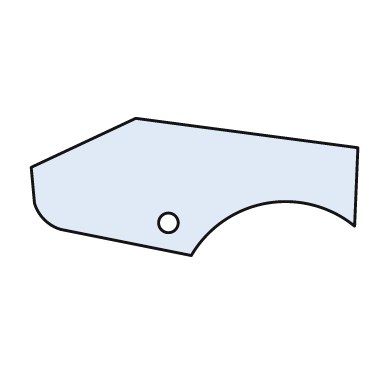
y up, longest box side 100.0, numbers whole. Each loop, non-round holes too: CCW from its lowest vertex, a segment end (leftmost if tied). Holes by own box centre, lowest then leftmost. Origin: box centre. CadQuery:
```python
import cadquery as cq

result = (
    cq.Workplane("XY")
    .moveTo(-1.0, -21.0)
    .threePointArc((22.0, -5.0), (49.0, -12.0))
    .lineTo(50.0, 12.0)
    .lineTo(-18.0, 21.0)
    .lineTo(-50.0, 6.0)
    .lineTo(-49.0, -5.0)
    .threePointArc((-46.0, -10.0), (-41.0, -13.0))
    .close()
    .moveTo(-8.0, -11.0)
    .circle(3.0)
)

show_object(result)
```